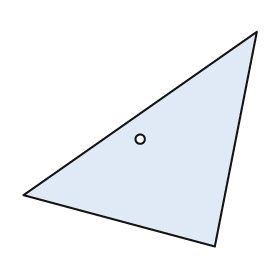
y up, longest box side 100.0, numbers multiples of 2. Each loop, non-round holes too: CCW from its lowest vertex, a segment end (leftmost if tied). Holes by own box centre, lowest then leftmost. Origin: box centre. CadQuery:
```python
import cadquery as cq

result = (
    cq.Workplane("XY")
    .moveTo(32.0, -46.0)
    .lineTo(50.0, 46.0)
    .lineTo(-50.0, -24.0)
    .close()
    .moveTo(0.0, 0.0)
    .circle(2.0)
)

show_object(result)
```